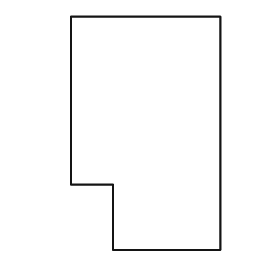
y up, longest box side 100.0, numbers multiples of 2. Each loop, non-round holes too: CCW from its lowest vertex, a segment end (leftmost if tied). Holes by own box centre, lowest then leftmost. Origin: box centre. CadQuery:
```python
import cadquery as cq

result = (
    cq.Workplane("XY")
    .moveTo(-14.0, -50.0)
    .lineTo(32.0, -50.0)
    .lineTo(32.0, 50.0)
    .lineTo(-32.0, 50.0)
    .lineTo(-32.0, -22.0)
    .lineTo(-14.0, -22.0)
    .close()
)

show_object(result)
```